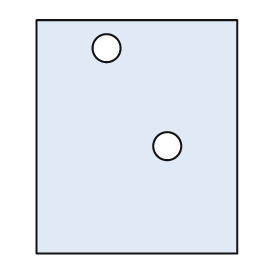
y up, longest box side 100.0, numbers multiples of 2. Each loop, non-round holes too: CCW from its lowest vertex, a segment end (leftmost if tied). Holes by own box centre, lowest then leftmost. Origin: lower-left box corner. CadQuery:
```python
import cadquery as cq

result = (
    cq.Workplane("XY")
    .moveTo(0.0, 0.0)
    .lineTo(86.0, 0.0)
    .lineTo(86.0, 100.0)
    .lineTo(0.0, 100.0)
    .close()
    .moveTo(56.0, 46.0)
    .circle(6.0)
    .moveTo(30.0, 88.0)
    .circle(6.0)
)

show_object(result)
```